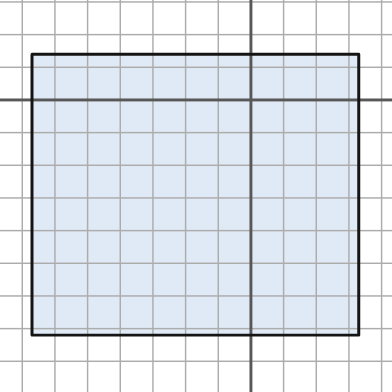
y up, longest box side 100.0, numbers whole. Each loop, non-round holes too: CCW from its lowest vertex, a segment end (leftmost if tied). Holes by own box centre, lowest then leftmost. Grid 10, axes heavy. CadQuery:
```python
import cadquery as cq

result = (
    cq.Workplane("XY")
    .moveTo(-67.0, -72.0)
    .lineTo(33.0, -72.0)
    .lineTo(33.0, 14.0)
    .lineTo(-67.0, 14.0)
    .close()
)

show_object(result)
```